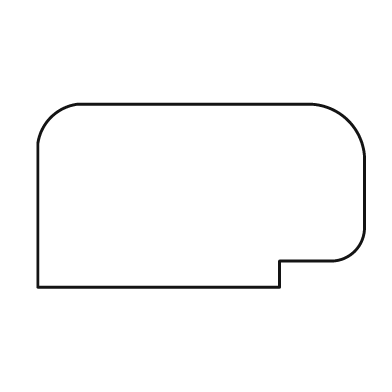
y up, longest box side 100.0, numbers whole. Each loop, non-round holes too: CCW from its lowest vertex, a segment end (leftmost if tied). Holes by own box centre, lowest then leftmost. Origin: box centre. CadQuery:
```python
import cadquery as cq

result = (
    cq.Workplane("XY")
    .moveTo(-50.0, -28.0)
    .lineTo(24.0, -28.0)
    .lineTo(24.0, -20.0)
    .lineTo(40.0, -20.0)
    .threePointArc((47.0, -17.0), (50.0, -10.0))
    .lineTo(50.0, 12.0)
    .threePointArc((45.0, 23.0), (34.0, 28.0))
    .lineTo(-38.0, 28.0)
    .threePointArc((-46.0, 24.0), (-50.0, 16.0))
    .close()
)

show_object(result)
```